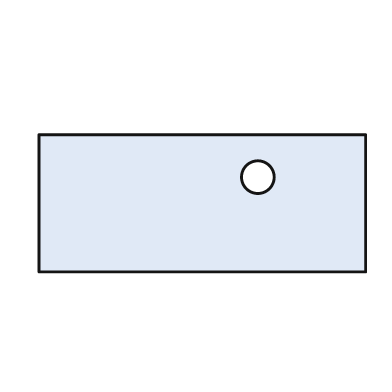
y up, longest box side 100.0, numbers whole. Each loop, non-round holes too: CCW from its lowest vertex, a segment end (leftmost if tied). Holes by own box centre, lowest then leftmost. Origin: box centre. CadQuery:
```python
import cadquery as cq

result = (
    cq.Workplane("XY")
    .moveTo(-50.0, -21.0)
    .lineTo(50.0, -21.0)
    .lineTo(50.0, 21.0)
    .lineTo(-50.0, 21.0)
    .close()
    .moveTo(17.0, 8.0)
    .circle(5.0)
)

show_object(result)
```